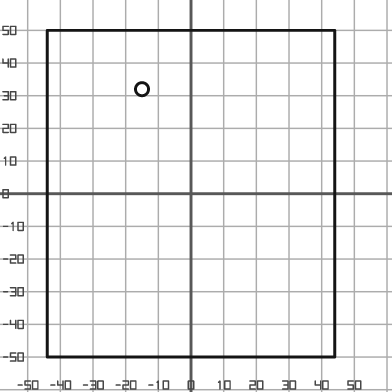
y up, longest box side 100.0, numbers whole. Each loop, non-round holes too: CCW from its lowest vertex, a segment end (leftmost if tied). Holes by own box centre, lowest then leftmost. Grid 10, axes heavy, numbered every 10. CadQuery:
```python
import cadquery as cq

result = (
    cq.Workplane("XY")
    .moveTo(-44.0, -50.0)
    .lineTo(44.0, -50.0)
    .lineTo(44.0, 50.0)
    .lineTo(-44.0, 50.0)
    .close()
    .moveTo(-15.0, 32.0)
    .circle(2.0)
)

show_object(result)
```